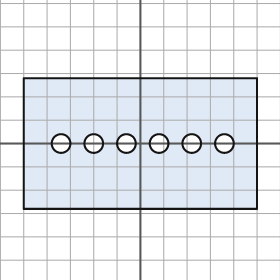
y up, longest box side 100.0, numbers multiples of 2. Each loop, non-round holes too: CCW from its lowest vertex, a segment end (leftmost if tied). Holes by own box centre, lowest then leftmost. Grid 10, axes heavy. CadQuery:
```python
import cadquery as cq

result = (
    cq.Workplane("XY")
    .moveTo(-50.0, -28.0)
    .lineTo(50.0, -28.0)
    .lineTo(50.0, 28.0)
    .lineTo(-50.0, 28.0)
    .close()
    .moveTo(-34.0, 0.0)
    .circle(4.0)
    .moveTo(-20.0, 0.0)
    .circle(4.0)
    .moveTo(-6.0, 0.0)
    .circle(4.0)
    .moveTo(8.0, 0.0)
    .circle(4.0)
    .moveTo(22.0, 0.0)
    .circle(4.0)
    .moveTo(36.0, 0.0)
    .circle(4.0)
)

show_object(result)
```